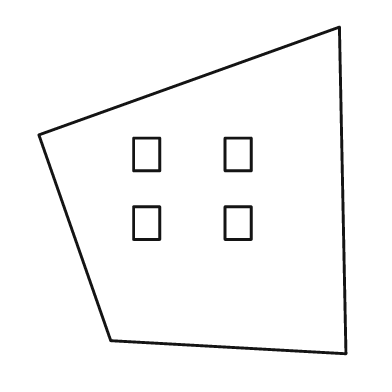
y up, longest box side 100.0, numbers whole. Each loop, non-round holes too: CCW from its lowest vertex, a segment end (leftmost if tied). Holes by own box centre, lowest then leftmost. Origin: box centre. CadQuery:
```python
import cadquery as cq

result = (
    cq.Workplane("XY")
    .moveTo(47.0, -50.0)
    .lineTo(45.0, 50.0)
    .lineTo(-47.0, 17.0)
    .lineTo(-25.0, -46.0)
    .close()
    .moveTo(-18.0, -15.0)
    .lineTo(-10.0, -15.0)
    .lineTo(-10.0, -5.0)
    .lineTo(-18.0, -5.0)
    .close()
    .moveTo(10.0, -15.0)
    .lineTo(18.0, -15.0)
    .lineTo(18.0, -5.0)
    .lineTo(10.0, -5.0)
    .close()
    .moveTo(-18.0, 6.0)
    .lineTo(-10.0, 6.0)
    .lineTo(-10.0, 16.0)
    .lineTo(-18.0, 16.0)
    .close()
    .moveTo(10.0, 6.0)
    .lineTo(18.0, 6.0)
    .lineTo(18.0, 16.0)
    .lineTo(10.0, 16.0)
    .close()
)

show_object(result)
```